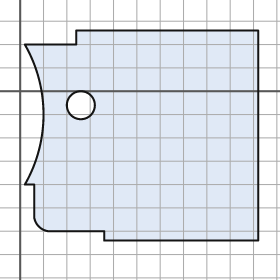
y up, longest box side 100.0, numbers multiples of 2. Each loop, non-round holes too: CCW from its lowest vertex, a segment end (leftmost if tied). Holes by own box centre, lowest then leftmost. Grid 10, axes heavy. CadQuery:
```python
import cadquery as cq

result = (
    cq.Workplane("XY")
    .moveTo(36.0, -64.0)
    .lineTo(102.0, -64.0)
    .lineTo(102.0, 26.0)
    .lineTo(24.0, 26.0)
    .lineTo(24.0, 20.0)
    .lineTo(2.0, 20.0)
    .threePointArc((10.0, -10.0), (2.0, -40.0))
    .lineTo(6.0, -40.0)
    .lineTo(6.0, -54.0)
    .threePointArc((8.0, -58.0), (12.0, -60.0))
    .lineTo(36.0, -60.0)
    .close()
    .moveTo(26.0, -6.0)
    .circle(6.0)
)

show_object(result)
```